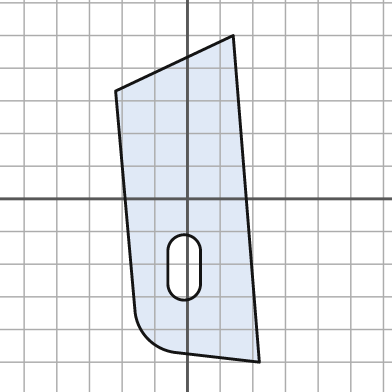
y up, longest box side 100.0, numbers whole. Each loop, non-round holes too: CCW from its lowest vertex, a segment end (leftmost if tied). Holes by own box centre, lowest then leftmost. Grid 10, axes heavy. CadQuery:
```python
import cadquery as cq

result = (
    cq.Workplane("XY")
    .moveTo(22.0, -50.0)
    .lineTo(14.0, 50.0)
    .lineTo(-22.0, 33.0)
    .lineTo(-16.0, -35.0)
    .threePointArc((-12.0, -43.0), (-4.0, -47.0))
    .close()
    .moveTo(-6.0, -26.0)
    .threePointArc((-1.0, -31.0), (4.0, -26.0))
    .lineTo(4.0, -16.0)
    .threePointArc((-1.0, -11.0), (-6.0, -16.0))
    .close()
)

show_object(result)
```